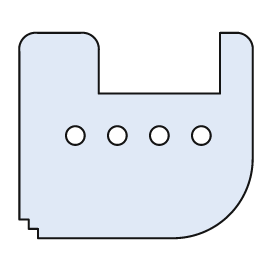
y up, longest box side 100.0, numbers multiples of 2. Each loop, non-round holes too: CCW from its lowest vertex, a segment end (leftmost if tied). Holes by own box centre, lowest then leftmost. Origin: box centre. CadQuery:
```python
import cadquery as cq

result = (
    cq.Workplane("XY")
    .moveTo(-42.0, -44.0)
    .lineTo(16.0, -44.0)
    .threePointArc((40.0, -34.0), (50.0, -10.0))
    .lineTo(50.0, 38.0)
    .threePointArc((48.0, 42.0), (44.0, 44.0))
    .lineTo(36.0, 44.0)
    .lineTo(36.0, 18.0)
    .lineTo(-16.0, 18.0)
    .lineTo(-16.0, 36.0)
    .threePointArc((-18.0, 42.0), (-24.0, 44.0))
    .lineTo(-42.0, 44.0)
    .threePointArc((-48.0, 42.0), (-50.0, 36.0))
    .lineTo(-50.0, -36.0)
    .lineTo(-46.0, -36.0)
    .lineTo(-46.0, -40.0)
    .lineTo(-42.0, -40.0)
    .close()
    .moveTo(-26.0, 0.0)
    .circle(4.0)
    .moveTo(-8.0, 0.0)
    .circle(4.0)
    .moveTo(10.0, 0.0)
    .circle(4.0)
    .moveTo(28.0, 0.0)
    .circle(4.0)
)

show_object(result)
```